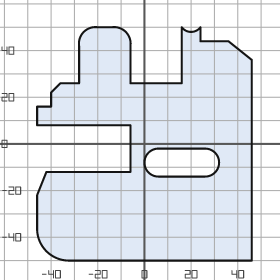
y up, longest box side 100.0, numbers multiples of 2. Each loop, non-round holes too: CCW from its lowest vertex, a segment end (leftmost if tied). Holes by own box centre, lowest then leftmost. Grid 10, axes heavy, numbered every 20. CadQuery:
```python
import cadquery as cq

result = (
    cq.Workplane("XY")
    .moveTo(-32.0, -50.0)
    .lineTo(46.0, -50.0)
    .lineTo(46.0, 36.0)
    .lineTo(36.0, 44.0)
    .lineTo(24.0, 44.0)
    .lineTo(24.0, 50.0)
    .threePointArc((20.0, 48.0), (16.0, 50.0))
    .lineTo(16.0, 26.0)
    .lineTo(-6.0, 26.0)
    .lineTo(-6.0, 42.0)
    .threePointArc((-8.0, 48.0), (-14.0, 50.0))
    .lineTo(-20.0, 50.0)
    .threePointArc((-26.0, 48.0), (-28.0, 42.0))
    .lineTo(-28.0, 26.0)
    .lineTo(-36.0, 26.0)
    .lineTo(-40.0, 22.0)
    .lineTo(-40.0, 16.0)
    .lineTo(-46.0, 16.0)
    .lineTo(-46.0, 8.0)
    .lineTo(-6.0, 8.0)
    .lineTo(-6.0, -12.0)
    .lineTo(-42.0, -12.0)
    .lineTo(-46.0, -22.0)
    .lineTo(-46.0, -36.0)
    .threePointArc((-42.0, -46.0), (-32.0, -50.0))
    .close()
    .moveTo(6.0, -14.0)
    .lineTo(26.0, -14.0)
    .threePointArc((32.0, -8.0), (26.0, -2.0))
    .lineTo(6.0, -2.0)
    .threePointArc((0.0, -8.0), (6.0, -14.0))
    .close()
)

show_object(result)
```